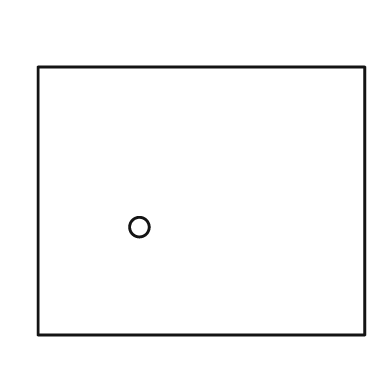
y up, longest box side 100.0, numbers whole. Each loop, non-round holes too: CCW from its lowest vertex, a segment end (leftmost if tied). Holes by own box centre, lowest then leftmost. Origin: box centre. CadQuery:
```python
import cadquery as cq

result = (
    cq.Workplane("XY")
    .moveTo(-50.0, -41.0)
    .lineTo(50.0, -41.0)
    .lineTo(50.0, 41.0)
    .lineTo(-50.0, 41.0)
    .close()
    .moveTo(-19.0, -8.0)
    .circle(3.0)
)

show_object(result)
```